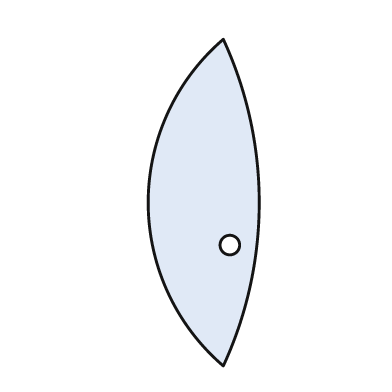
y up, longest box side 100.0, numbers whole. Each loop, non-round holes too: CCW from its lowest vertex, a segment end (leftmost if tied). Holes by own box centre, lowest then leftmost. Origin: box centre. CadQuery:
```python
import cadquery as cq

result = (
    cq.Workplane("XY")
    .moveTo(6.0, -50.0)
    .threePointArc((17.0, 0.0), (6.0, 50.0))
    .threePointArc((-17.0, 0.0), (6.0, -50.0))
    .close()
    .moveTo(8.0, -13.0)
    .circle(3.0)
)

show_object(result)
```